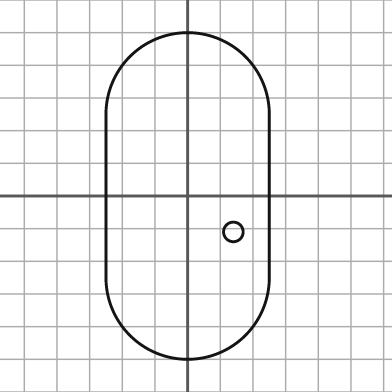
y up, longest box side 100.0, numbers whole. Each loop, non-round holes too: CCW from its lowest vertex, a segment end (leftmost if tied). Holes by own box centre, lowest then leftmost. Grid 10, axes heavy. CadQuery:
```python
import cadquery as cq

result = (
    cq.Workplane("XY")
    .moveTo(-25.0, -25.0)
    .threePointArc((0.0, -50.0), (25.0, -25.0))
    .lineTo(25.0, 25.0)
    .threePointArc((0.0, 50.0), (-25.0, 25.0))
    .close()
    .moveTo(14.0, -11.0)
    .circle(3.0)
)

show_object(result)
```